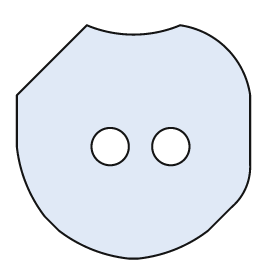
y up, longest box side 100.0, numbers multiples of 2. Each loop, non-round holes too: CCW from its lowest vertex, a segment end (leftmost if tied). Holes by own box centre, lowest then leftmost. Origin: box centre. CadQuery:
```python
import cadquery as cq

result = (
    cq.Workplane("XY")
    .moveTo(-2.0, -50.0)
    .lineTo(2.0, -50.0)
    .threePointArc((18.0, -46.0), (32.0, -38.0))
    .lineTo(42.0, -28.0)
    .threePointArc((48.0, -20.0), (50.0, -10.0))
    .lineTo(50.0, 20.0)
    .threePointArc((40.0, 40.0), (20.0, 50.0))
    .threePointArc((0.0, 46.0), (-20.0, 50.0))
    .lineTo(-50.0, 20.0)
    .lineTo(-50.0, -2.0)
    .threePointArc((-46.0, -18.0), (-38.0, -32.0))
    .lineTo(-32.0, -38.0)
    .threePointArc((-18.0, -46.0), (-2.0, -50.0))
    .close()
    .moveTo(-10.0, -2.0)
    .circle(8.0)
    .moveTo(16.0, -2.0)
    .circle(8.0)
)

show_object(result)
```